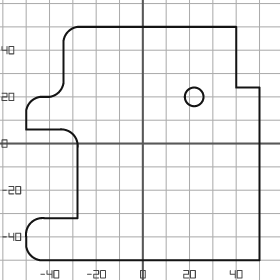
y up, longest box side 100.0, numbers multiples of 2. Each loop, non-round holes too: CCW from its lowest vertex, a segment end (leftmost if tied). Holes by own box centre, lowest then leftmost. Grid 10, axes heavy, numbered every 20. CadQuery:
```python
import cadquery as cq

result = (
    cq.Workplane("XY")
    .moveTo(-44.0, -50.0)
    .lineTo(50.0, -50.0)
    .lineTo(50.0, 24.0)
    .lineTo(40.0, 24.0)
    .lineTo(40.0, 50.0)
    .lineTo(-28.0, 50.0)
    .threePointArc((-32.0, 48.0), (-34.0, 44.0))
    .lineTo(-34.0, 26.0)
    .threePointArc((-36.0, 22.0), (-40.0, 20.0))
    .lineTo(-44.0, 20.0)
    .threePointArc((-48.0, 18.0), (-50.0, 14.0))
    .lineTo(-50.0, 6.0)
    .lineTo(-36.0, 6.0)
    .threePointArc((-30.0, 4.0), (-28.0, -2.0))
    .lineTo(-28.0, -32.0)
    .lineTo(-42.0, -32.0)
    .threePointArc((-48.0, -34.0), (-50.0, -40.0))
    .lineTo(-50.0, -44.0)
    .threePointArc((-48.0, -48.0), (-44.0, -50.0))
    .close()
    .moveTo(22.0, 20.0)
    .circle(4.0)
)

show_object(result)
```